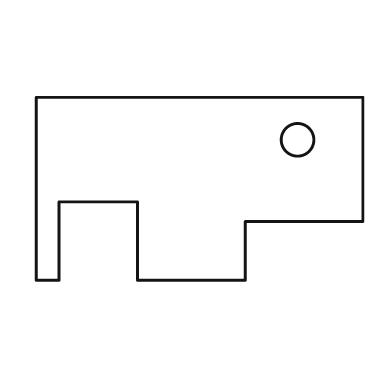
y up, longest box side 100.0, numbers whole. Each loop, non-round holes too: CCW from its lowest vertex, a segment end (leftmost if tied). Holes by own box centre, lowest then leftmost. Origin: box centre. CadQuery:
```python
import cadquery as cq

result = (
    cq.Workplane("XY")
    .moveTo(-50.0, -28.0)
    .lineTo(-43.0, -28.0)
    .lineTo(-43.0, -4.0)
    .lineTo(-19.0, -4.0)
    .lineTo(-19.0, -28.0)
    .lineTo(14.0, -28.0)
    .lineTo(14.0, -10.0)
    .lineTo(50.0, -10.0)
    .lineTo(50.0, 28.0)
    .lineTo(-50.0, 28.0)
    .close()
    .moveTo(30.0, 15.0)
    .circle(5.0)
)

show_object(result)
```